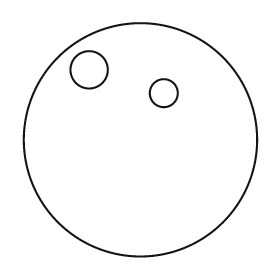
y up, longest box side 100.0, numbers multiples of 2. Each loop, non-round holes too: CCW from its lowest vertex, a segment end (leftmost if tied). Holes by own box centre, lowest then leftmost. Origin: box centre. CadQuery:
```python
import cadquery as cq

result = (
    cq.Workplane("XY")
    .moveTo(0.0, 0.0)
    .circle(50.0)
    .moveTo(10.0, 20.0)
    .circle(6.0)
    .moveTo(-22.0, 30.0)
    .circle(8.0)
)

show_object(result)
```